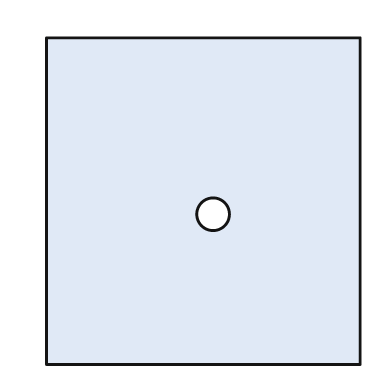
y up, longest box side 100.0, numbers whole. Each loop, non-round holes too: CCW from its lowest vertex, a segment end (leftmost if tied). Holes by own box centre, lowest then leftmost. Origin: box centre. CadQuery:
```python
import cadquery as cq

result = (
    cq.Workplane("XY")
    .moveTo(-48.0, -50.0)
    .lineTo(48.0, -50.0)
    .lineTo(48.0, 50.0)
    .lineTo(-48.0, 50.0)
    .close()
    .moveTo(3.0, -4.0)
    .circle(5.0)
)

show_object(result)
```